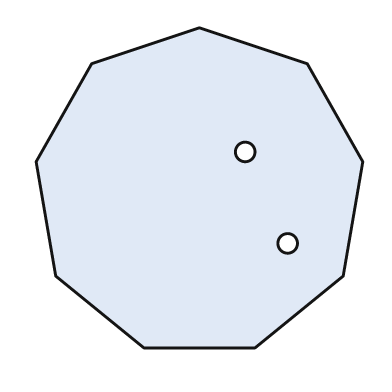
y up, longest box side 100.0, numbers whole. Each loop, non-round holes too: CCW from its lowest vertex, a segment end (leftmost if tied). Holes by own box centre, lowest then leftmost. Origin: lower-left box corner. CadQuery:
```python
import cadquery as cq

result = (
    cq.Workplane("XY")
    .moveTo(33.0, 0.0)
    .lineTo(67.0, 0.0)
    .lineTo(94.0, 22.0)
    .lineTo(100.0, 57.0)
    .lineTo(83.0, 87.0)
    .lineTo(50.0, 98.0)
    .lineTo(17.0, 87.0)
    .lineTo(0.0, 57.0)
    .lineTo(6.0, 22.0)
    .close()
    .moveTo(77.0, 32.0)
    .circle(3.0)
    .moveTo(64.0, 60.0)
    .circle(3.0)
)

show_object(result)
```